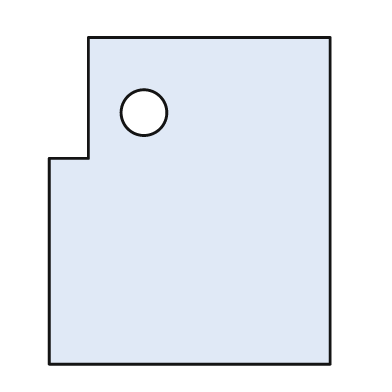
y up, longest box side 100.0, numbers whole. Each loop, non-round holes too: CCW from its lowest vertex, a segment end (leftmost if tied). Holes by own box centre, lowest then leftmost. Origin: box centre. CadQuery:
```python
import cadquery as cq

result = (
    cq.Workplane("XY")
    .moveTo(-43.0, -50.0)
    .lineTo(43.0, -50.0)
    .lineTo(43.0, 50.0)
    .lineTo(-31.0, 50.0)
    .lineTo(-31.0, 13.0)
    .lineTo(-43.0, 13.0)
    .close()
    .moveTo(-14.0, 27.0)
    .circle(7.0)
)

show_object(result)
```